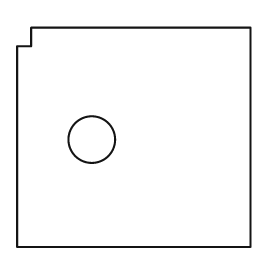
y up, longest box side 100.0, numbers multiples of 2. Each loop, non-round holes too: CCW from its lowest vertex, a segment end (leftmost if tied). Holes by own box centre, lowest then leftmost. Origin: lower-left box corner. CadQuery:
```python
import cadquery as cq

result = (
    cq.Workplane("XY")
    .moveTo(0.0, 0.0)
    .lineTo(100.0, 0.0)
    .lineTo(100.0, 94.0)
    .lineTo(6.0, 94.0)
    .lineTo(6.0, 86.0)
    .lineTo(0.0, 86.0)
    .close()
    .moveTo(32.0, 46.0)
    .circle(10.0)
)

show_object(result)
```